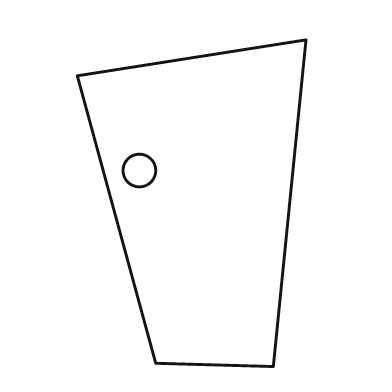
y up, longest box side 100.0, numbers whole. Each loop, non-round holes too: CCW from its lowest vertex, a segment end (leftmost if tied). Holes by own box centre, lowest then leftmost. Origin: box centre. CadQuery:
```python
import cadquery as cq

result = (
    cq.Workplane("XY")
    .moveTo(25.0, -50.0)
    .lineTo(35.0, 50.0)
    .lineTo(-35.0, 39.0)
    .lineTo(-11.0, -49.0)
    .close()
    .moveTo(-16.0, 10.0)
    .circle(5.0)
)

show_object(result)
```